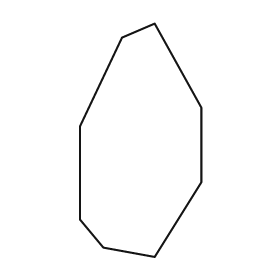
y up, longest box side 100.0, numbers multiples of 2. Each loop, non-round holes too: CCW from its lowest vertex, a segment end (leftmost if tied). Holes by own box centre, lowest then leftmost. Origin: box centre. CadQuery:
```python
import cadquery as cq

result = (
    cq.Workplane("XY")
    .moveTo(6.0, -50.0)
    .lineTo(26.0, -18.0)
    .lineTo(26.0, 14.0)
    .lineTo(6.0, 50.0)
    .lineTo(-8.0, 44.0)
    .lineTo(-26.0, 6.0)
    .lineTo(-26.0, -34.0)
    .lineTo(-16.0, -46.0)
    .close()
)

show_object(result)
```